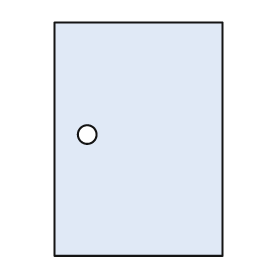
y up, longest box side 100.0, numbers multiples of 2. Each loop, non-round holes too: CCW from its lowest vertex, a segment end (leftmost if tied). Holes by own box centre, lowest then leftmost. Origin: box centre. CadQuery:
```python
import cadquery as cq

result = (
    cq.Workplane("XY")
    .moveTo(-36.0, -50.0)
    .lineTo(36.0, -50.0)
    .lineTo(36.0, 50.0)
    .lineTo(-36.0, 50.0)
    .close()
    .moveTo(-22.0, 2.0)
    .circle(4.0)
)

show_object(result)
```